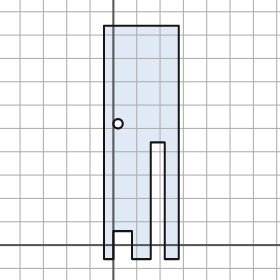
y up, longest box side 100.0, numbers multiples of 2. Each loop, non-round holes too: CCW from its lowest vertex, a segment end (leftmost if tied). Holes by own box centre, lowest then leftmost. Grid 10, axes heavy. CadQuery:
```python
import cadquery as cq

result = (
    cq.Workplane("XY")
    .moveTo(-4.0, -6.0)
    .lineTo(0.0, -6.0)
    .lineTo(0.0, 6.0)
    .lineTo(8.0, 6.0)
    .lineTo(8.0, -6.0)
    .lineTo(16.0, -6.0)
    .lineTo(16.0, 44.0)
    .lineTo(22.0, 44.0)
    .lineTo(22.0, -6.0)
    .lineTo(28.0, -6.0)
    .lineTo(28.0, 94.0)
    .lineTo(-4.0, 94.0)
    .close()
    .moveTo(2.0, 52.0)
    .circle(2.0)
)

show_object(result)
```